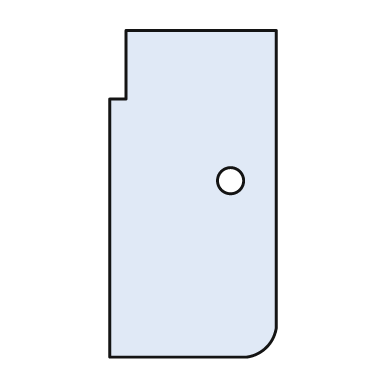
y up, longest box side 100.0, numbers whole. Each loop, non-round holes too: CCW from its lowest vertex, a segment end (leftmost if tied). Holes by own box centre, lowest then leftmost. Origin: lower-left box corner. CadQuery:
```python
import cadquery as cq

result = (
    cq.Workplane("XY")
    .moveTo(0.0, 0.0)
    .lineTo(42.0, 0.0)
    .threePointArc((48.0, 3.0), (51.0, 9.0))
    .lineTo(51.0, 100.0)
    .lineTo(5.0, 100.0)
    .lineTo(5.0, 79.0)
    .lineTo(0.0, 79.0)
    .close()
    .moveTo(37.0, 54.0)
    .circle(4.0)
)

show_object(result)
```